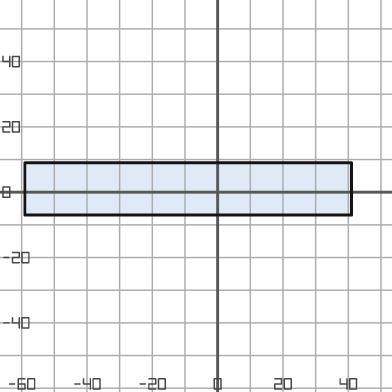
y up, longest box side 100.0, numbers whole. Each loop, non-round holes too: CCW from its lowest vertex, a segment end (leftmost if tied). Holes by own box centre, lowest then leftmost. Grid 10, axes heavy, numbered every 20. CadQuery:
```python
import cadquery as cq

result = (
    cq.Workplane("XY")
    .moveTo(-59.0, -7.0)
    .lineTo(41.0, -7.0)
    .lineTo(41.0, 9.0)
    .lineTo(-59.0, 9.0)
    .close()
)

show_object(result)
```